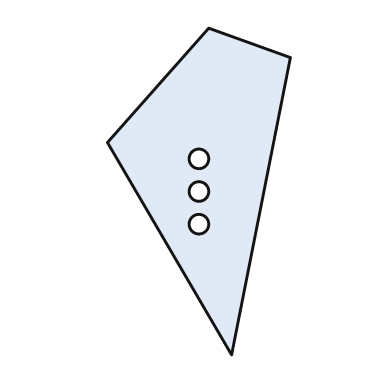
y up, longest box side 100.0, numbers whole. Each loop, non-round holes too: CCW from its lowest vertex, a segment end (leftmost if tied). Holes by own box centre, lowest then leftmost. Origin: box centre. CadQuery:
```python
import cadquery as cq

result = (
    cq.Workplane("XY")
    .moveTo(10.0, -50.0)
    .lineTo(28.0, 41.0)
    .lineTo(3.0, 50.0)
    .lineTo(-28.0, 15.0)
    .close()
    .moveTo(0.0, -10.0)
    .circle(3.0)
    .moveTo(0.0, 0.0)
    .circle(3.0)
    .moveTo(0.0, 10.0)
    .circle(3.0)
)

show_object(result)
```